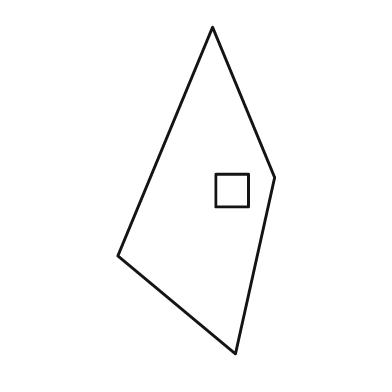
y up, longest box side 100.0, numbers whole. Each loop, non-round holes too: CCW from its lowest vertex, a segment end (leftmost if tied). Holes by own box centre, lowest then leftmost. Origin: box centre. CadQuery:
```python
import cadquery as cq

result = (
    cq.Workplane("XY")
    .moveTo(12.0, -50.0)
    .lineTo(24.0, 4.0)
    .lineTo(5.0, 50.0)
    .lineTo(-24.0, -20.0)
    .close()
    .moveTo(6.0, -5.0)
    .lineTo(16.0, -5.0)
    .lineTo(16.0, 5.0)
    .lineTo(6.0, 5.0)
    .close()
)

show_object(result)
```